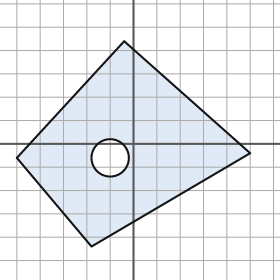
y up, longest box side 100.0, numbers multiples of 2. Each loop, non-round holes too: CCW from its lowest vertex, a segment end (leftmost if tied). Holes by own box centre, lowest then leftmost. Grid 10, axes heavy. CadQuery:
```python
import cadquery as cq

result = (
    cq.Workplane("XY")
    .moveTo(-18.0, -44.0)
    .lineTo(50.0, -4.0)
    .lineTo(-4.0, 44.0)
    .lineTo(-50.0, -6.0)
    .close()
    .moveTo(-10.0, -6.0)
    .circle(8.0)
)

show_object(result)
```